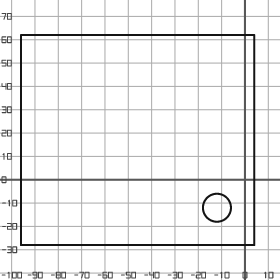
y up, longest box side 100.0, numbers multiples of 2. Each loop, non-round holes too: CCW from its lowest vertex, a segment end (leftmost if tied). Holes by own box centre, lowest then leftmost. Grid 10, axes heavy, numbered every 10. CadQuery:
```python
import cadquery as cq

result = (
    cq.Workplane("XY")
    .moveTo(-96.0, -28.0)
    .lineTo(4.0, -28.0)
    .lineTo(4.0, 62.0)
    .lineTo(-96.0, 62.0)
    .close()
    .moveTo(-12.0, -12.0)
    .circle(6.0)
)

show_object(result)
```